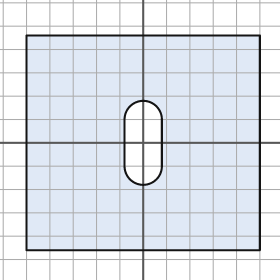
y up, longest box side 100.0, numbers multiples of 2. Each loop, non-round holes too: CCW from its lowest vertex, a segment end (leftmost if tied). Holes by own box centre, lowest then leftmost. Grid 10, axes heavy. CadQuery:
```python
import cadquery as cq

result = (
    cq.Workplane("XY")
    .moveTo(-50.0, -46.0)
    .lineTo(50.0, -46.0)
    .lineTo(50.0, 46.0)
    .lineTo(-50.0, 46.0)
    .close()
    .moveTo(-8.0, -10.0)
    .threePointArc((0.0, -18.0), (8.0, -10.0))
    .lineTo(8.0, 10.0)
    .threePointArc((0.0, 18.0), (-8.0, 10.0))
    .close()
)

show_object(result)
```